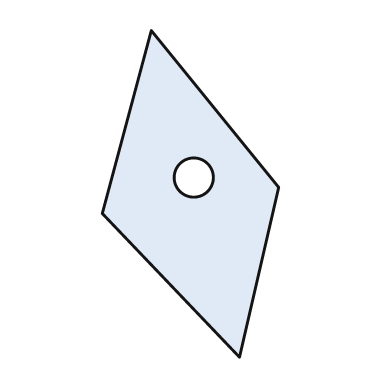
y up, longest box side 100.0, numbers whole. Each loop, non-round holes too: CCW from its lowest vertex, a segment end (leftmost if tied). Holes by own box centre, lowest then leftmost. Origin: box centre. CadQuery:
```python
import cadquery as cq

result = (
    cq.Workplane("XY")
    .moveTo(15.0, -50.0)
    .lineTo(27.0, 2.0)
    .lineTo(-12.0, 50.0)
    .lineTo(-27.0, -6.0)
    .close()
    .moveTo(1.0, 5.0)
    .circle(6.0)
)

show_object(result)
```